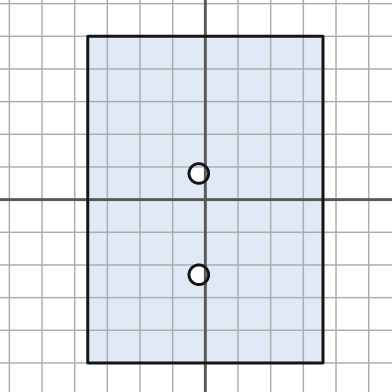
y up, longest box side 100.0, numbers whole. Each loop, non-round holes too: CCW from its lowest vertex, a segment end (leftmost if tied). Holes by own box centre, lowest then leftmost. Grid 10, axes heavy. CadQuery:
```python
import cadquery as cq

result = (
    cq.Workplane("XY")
    .moveTo(-36.0, -50.0)
    .lineTo(36.0, -50.0)
    .lineTo(36.0, 50.0)
    .lineTo(-36.0, 50.0)
    .close()
    .moveTo(-2.0, -23.0)
    .circle(3.0)
    .moveTo(-2.0, 8.0)
    .circle(3.0)
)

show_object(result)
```